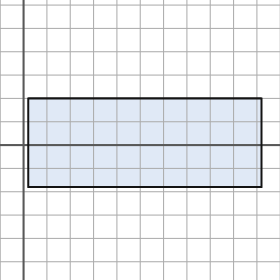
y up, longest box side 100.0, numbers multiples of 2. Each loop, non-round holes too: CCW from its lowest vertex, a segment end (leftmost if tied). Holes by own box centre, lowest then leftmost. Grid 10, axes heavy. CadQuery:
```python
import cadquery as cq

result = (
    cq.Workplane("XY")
    .moveTo(2.0, -18.0)
    .lineTo(102.0, -18.0)
    .lineTo(102.0, 20.0)
    .lineTo(2.0, 20.0)
    .close()
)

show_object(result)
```